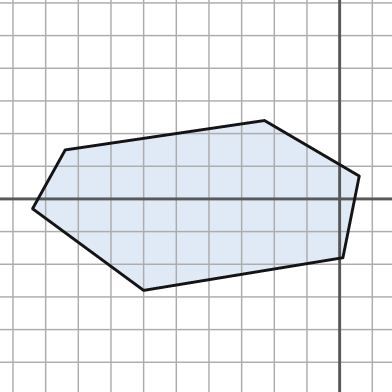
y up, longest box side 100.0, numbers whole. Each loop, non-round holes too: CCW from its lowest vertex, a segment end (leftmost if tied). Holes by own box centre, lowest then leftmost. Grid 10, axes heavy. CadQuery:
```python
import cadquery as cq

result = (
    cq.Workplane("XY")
    .moveTo(-60.0, -28.0)
    .lineTo(1.0, -18.0)
    .lineTo(6.0, 7.0)
    .lineTo(-23.0, 24.0)
    .lineTo(-84.0, 15.0)
    .lineTo(-94.0, -3.0)
    .close()
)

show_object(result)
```